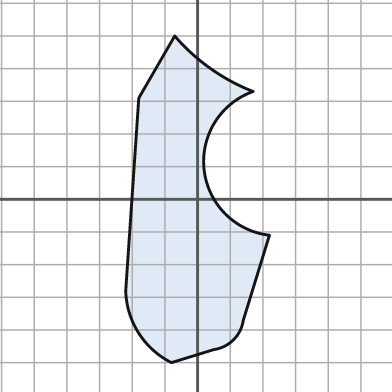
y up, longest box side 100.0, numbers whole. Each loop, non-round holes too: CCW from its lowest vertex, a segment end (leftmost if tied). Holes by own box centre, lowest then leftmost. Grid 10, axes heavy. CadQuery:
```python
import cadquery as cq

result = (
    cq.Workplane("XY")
    .moveTo(-8.0, -50.0)
    .lineTo(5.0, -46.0)
    .threePointArc((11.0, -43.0), (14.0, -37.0))
    .lineTo(22.0, -11.0)
    .threePointArc((2.0, 9.0), (17.0, 33.0))
    .threePointArc((4.0, 40.0), (-7.0, 50.0))
    .lineTo(-18.0, 31.0)
    .lineTo(-22.0, -28.0)
    .threePointArc((-18.0, -41.0), (-8.0, -50.0))
    .close()
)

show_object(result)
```